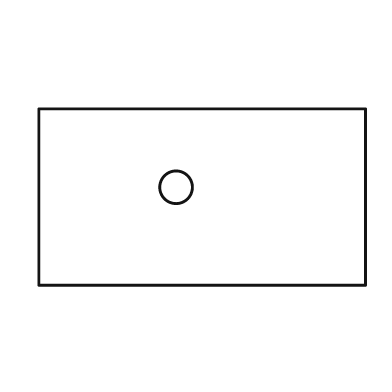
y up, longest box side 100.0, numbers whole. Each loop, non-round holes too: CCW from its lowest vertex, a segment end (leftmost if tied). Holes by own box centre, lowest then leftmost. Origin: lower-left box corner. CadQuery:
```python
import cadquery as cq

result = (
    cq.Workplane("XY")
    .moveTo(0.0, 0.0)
    .lineTo(100.0, 0.0)
    .lineTo(100.0, 54.0)
    .lineTo(0.0, 54.0)
    .close()
    .moveTo(42.0, 30.0)
    .circle(5.0)
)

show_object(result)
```